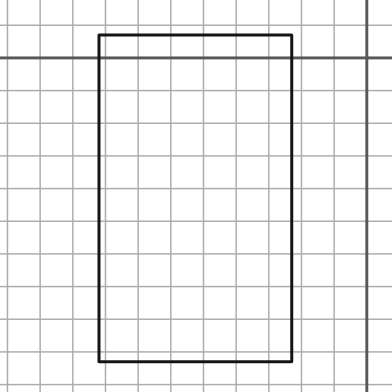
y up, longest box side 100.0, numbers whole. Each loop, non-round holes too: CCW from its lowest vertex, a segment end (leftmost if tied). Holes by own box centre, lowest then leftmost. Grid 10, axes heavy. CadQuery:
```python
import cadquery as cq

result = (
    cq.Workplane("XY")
    .moveTo(-82.0, -93.0)
    .lineTo(-23.0, -93.0)
    .lineTo(-23.0, 7.0)
    .lineTo(-82.0, 7.0)
    .close()
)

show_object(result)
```